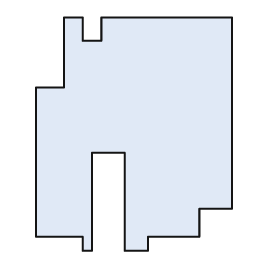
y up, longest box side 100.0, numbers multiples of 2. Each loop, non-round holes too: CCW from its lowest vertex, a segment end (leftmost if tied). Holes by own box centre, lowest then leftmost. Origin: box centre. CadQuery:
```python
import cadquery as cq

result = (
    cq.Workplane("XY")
    .moveTo(-22.0, -50.0)
    .lineTo(-18.0, -50.0)
    .lineTo(-18.0, -8.0)
    .lineTo(-4.0, -8.0)
    .lineTo(-4.0, -50.0)
    .lineTo(6.0, -50.0)
    .lineTo(6.0, -44.0)
    .lineTo(28.0, -44.0)
    .lineTo(28.0, -32.0)
    .lineTo(42.0, -32.0)
    .lineTo(42.0, 50.0)
    .lineTo(-14.0, 50.0)
    .lineTo(-14.0, 40.0)
    .lineTo(-22.0, 40.0)
    .lineTo(-22.0, 50.0)
    .lineTo(-30.0, 50.0)
    .lineTo(-30.0, 20.0)
    .lineTo(-42.0, 20.0)
    .lineTo(-42.0, -44.0)
    .lineTo(-22.0, -44.0)
    .close()
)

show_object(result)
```